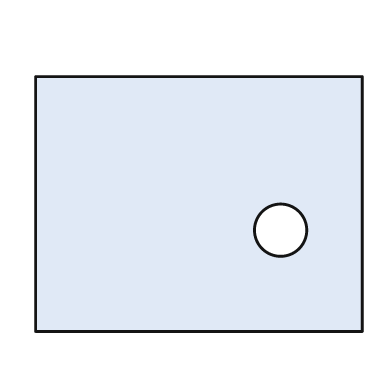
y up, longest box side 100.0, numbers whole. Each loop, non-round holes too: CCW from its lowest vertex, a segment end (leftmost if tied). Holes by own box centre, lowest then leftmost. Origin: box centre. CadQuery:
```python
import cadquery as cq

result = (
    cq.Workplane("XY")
    .moveTo(-50.0, -39.0)
    .lineTo(50.0, -39.0)
    .lineTo(50.0, 39.0)
    .lineTo(-50.0, 39.0)
    .close()
    .moveTo(25.0, -8.0)
    .circle(8.0)
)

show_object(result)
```